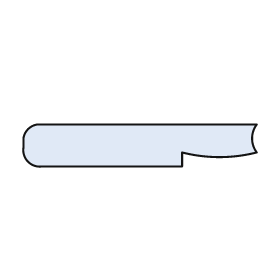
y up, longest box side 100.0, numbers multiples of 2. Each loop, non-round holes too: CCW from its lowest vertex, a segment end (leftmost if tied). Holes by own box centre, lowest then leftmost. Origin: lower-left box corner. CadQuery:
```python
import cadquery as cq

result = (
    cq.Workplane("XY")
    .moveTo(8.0, 0.0)
    .lineTo(68.0, 0.0)
    .lineTo(68.0, 6.0)
    .threePointArc((84.0, 4.0), (100.0, 6.0))
    .threePointArc((98.0, 12.0), (100.0, 18.0))
    .lineTo(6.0, 18.0)
    .threePointArc((2.0, 16.0), (0.0, 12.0))
    .lineTo(0.0, 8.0)
    .threePointArc((2.0, 2.0), (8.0, 0.0))
    .close()
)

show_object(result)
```